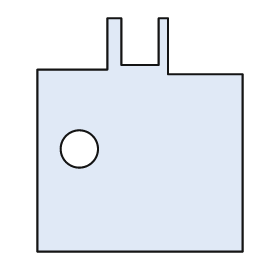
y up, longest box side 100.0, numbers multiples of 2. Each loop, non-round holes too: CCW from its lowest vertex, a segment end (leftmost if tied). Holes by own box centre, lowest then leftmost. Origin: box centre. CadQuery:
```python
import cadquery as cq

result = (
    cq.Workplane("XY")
    .moveTo(-44.0, -50.0)
    .lineTo(44.0, -50.0)
    .lineTo(44.0, 26.0)
    .lineTo(12.0, 26.0)
    .lineTo(12.0, 50.0)
    .lineTo(8.0, 50.0)
    .lineTo(8.0, 30.0)
    .lineTo(-8.0, 30.0)
    .lineTo(-8.0, 50.0)
    .lineTo(-14.0, 50.0)
    .lineTo(-14.0, 28.0)
    .lineTo(-44.0, 28.0)
    .close()
    .moveTo(-26.0, -6.0)
    .circle(8.0)
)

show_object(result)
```